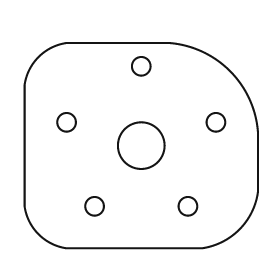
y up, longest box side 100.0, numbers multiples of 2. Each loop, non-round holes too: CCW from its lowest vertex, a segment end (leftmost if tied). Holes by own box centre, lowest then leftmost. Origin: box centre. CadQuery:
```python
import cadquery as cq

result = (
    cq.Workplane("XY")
    .moveTo(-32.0, -44.0)
    .lineTo(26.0, -44.0)
    .threePointArc((42.0, -36.0), (50.0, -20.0))
    .lineTo(50.0, 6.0)
    .threePointArc((38.0, 32.0), (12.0, 44.0))
    .lineTo(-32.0, 44.0)
    .threePointArc((-44.0, 38.0), (-50.0, 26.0))
    .lineTo(-50.0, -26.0)
    .threePointArc((-44.0, -38.0), (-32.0, -44.0))
    .close()
    .moveTo(-20.0, -26.0)
    .circle(4.0)
    .moveTo(20.0, -26.0)
    .circle(4.0)
    .moveTo(0.0, 0.0)
    .circle(10.0)
    .moveTo(-32.0, 10.0)
    .circle(4.0)
    .moveTo(32.0, 10.0)
    .circle(4.0)
    .moveTo(0.0, 34.0)
    .circle(4.0)
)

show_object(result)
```